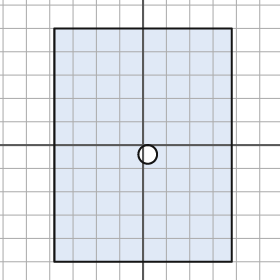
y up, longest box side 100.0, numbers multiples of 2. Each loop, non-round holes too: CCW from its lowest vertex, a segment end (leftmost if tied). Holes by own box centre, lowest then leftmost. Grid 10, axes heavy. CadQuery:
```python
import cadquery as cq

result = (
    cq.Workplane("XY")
    .moveTo(-38.0, -50.0)
    .lineTo(38.0, -50.0)
    .lineTo(38.0, 50.0)
    .lineTo(-38.0, 50.0)
    .close()
    .moveTo(2.0, -4.0)
    .circle(4.0)
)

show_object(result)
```